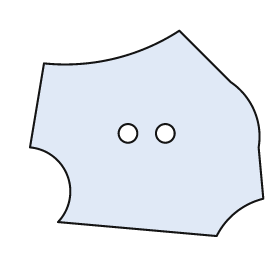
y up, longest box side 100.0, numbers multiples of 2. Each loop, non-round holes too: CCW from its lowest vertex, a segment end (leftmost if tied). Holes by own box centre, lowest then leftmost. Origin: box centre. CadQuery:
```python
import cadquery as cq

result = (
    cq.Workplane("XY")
    .moveTo(30.0, -44.0)
    .threePointArc((38.0, -34.0), (50.0, -28.0))
    .lineTo(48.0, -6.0)
    .threePointArc((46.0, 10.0), (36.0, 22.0))
    .lineTo(14.0, 44.0)
    .threePointArc((-14.0, 32.0), (-44.0, 30.0))
    .lineTo(-50.0, -6.0)
    .threePointArc((-34.0, -18.0), (-38.0, -38.0))
    .close()
    .moveTo(-8.0, 0.0)
    .circle(4.0)
    .moveTo(8.0, 0.0)
    .circle(4.0)
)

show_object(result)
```